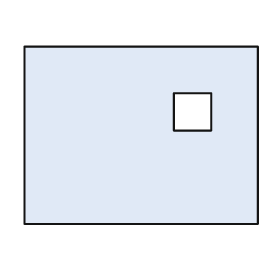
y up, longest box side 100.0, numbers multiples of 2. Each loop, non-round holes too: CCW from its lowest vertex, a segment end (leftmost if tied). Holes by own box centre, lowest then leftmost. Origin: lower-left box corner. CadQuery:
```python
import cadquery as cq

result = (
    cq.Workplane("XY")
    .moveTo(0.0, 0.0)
    .lineTo(100.0, 0.0)
    .lineTo(100.0, 76.0)
    .lineTo(0.0, 76.0)
    .close()
    .moveTo(64.0, 40.0)
    .lineTo(80.0, 40.0)
    .lineTo(80.0, 56.0)
    .lineTo(64.0, 56.0)
    .close()
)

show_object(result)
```